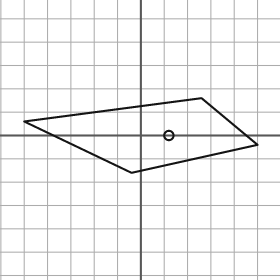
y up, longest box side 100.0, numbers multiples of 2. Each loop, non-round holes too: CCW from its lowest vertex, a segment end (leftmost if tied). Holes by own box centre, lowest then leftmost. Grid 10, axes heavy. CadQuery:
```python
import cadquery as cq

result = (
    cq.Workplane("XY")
    .moveTo(-4.0, -16.0)
    .lineTo(50.0, -4.0)
    .lineTo(26.0, 16.0)
    .lineTo(-50.0, 6.0)
    .close()
    .moveTo(12.0, 0.0)
    .circle(2.0)
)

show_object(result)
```